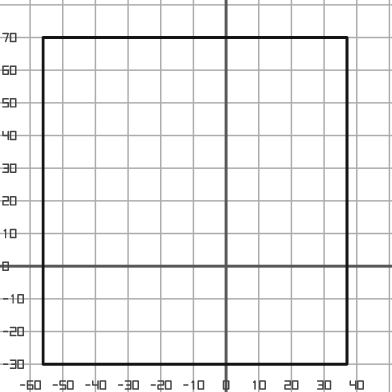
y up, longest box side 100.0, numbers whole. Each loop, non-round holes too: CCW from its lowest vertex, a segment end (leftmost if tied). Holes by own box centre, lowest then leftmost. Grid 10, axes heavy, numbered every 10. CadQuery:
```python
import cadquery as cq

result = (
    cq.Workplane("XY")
    .moveTo(-56.0, -30.0)
    .lineTo(37.0, -30.0)
    .lineTo(37.0, 70.0)
    .lineTo(-56.0, 70.0)
    .close()
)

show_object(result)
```